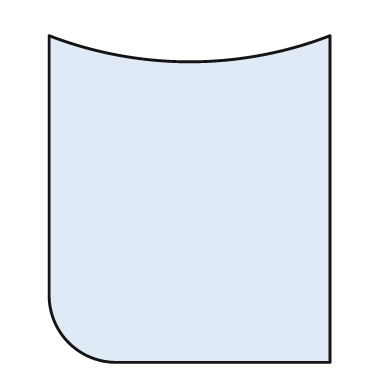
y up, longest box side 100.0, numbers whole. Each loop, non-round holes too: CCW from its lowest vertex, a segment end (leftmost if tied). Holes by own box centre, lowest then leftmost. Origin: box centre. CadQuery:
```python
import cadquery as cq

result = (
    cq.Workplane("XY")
    .moveTo(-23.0, -50.0)
    .lineTo(43.0, -50.0)
    .lineTo(43.0, 50.0)
    .threePointArc((0.0, 42.0), (-43.0, 50.0))
    .lineTo(-43.0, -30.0)
    .threePointArc((-37.0, -44.0), (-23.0, -50.0))
    .close()
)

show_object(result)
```